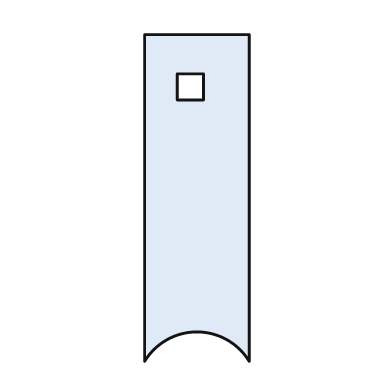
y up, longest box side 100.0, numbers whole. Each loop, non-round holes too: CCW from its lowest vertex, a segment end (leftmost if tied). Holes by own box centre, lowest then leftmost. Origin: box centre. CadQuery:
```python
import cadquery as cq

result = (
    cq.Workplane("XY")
    .moveTo(-16.0, -50.0)
    .threePointArc((0.0, -41.0), (16.0, -50.0))
    .lineTo(16.0, 50.0)
    .lineTo(-16.0, 50.0)
    .close()
    .moveTo(-6.0, 30.0)
    .lineTo(2.0, 30.0)
    .lineTo(2.0, 38.0)
    .lineTo(-6.0, 38.0)
    .close()
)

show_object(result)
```